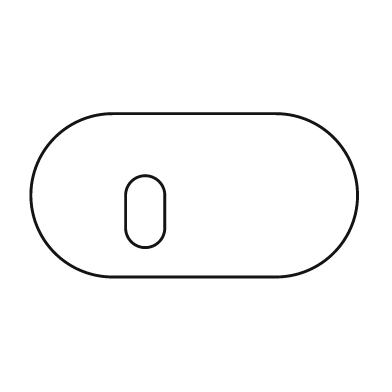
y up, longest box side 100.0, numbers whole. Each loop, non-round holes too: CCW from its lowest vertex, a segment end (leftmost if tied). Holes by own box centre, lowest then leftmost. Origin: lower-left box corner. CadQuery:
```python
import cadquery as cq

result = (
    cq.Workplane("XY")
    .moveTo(25.0, 0.0)
    .lineTo(75.0, 0.0)
    .threePointArc((100.0, 25.0), (75.0, 50.0))
    .lineTo(25.0, 50.0)
    .threePointArc((0.0, 25.0), (25.0, 0.0))
    .close()
    .moveTo(29.0, 15.0)
    .threePointArc((35.0, 9.0), (41.0, 15.0))
    .lineTo(41.0, 25.0)
    .threePointArc((35.0, 31.0), (29.0, 25.0))
    .close()
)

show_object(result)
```